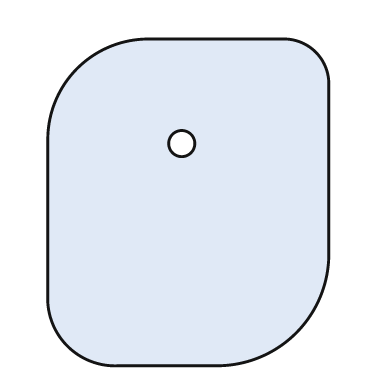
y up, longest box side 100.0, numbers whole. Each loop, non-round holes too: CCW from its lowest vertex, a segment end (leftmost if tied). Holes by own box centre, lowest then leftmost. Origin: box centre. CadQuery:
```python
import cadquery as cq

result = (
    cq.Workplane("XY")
    .moveTo(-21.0, -50.0)
    .lineTo(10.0, -50.0)
    .threePointArc((33.0, -40.0), (43.0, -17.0))
    .lineTo(43.0, 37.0)
    .threePointArc((39.0, 46.0), (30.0, 50.0))
    .lineTo(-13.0, 50.0)
    .threePointArc((-34.0, 41.0), (-43.0, 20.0))
    .lineTo(-43.0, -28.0)
    .threePointArc((-37.0, -44.0), (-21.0, -50.0))
    .close()
    .moveTo(-2.0, 18.0)
    .circle(4.0)
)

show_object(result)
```